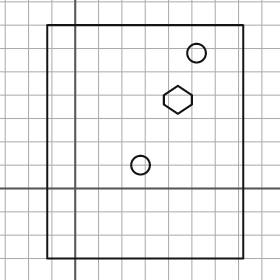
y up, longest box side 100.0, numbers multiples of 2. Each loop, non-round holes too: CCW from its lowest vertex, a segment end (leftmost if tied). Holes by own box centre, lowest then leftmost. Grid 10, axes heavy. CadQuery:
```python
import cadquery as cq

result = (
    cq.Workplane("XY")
    .moveTo(-12.0, -30.0)
    .lineTo(72.0, -30.0)
    .lineTo(72.0, 70.0)
    .lineTo(-12.0, 70.0)
    .close()
    .moveTo(28.0, 10.0)
    .circle(4.0)
    .moveTo(44.0, 32.0)
    .lineTo(50.0, 36.0)
    .lineTo(50.0, 40.0)
    .lineTo(44.0, 44.0)
    .lineTo(38.0, 40.0)
    .lineTo(38.0, 36.0)
    .close()
    .moveTo(52.0, 58.0)
    .circle(4.0)
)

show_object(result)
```